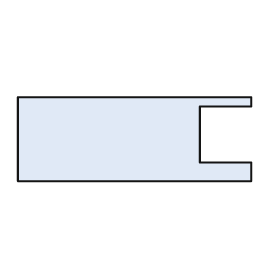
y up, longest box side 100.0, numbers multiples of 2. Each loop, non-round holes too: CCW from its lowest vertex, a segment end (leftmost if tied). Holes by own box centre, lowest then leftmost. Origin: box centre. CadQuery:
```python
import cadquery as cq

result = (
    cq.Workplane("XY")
    .moveTo(-50.0, -18.0)
    .lineTo(50.0, -18.0)
    .lineTo(50.0, -10.0)
    .lineTo(28.0, -10.0)
    .lineTo(28.0, 14.0)
    .lineTo(50.0, 14.0)
    .lineTo(50.0, 18.0)
    .lineTo(-50.0, 18.0)
    .close()
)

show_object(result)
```